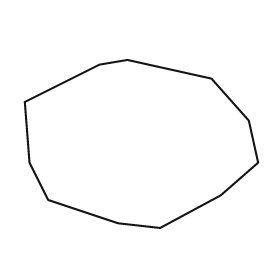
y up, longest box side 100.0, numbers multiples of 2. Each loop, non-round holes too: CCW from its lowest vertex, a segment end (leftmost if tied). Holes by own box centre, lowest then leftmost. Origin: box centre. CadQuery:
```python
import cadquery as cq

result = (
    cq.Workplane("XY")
    .moveTo(8.0, -36.0)
    .lineTo(34.0, -22.0)
    .lineTo(50.0, -8.0)
    .lineTo(46.0, 10.0)
    .lineTo(30.0, 28.0)
    .lineTo(-6.0, 36.0)
    .lineTo(-18.0, 34.0)
    .lineTo(-50.0, 18.0)
    .lineTo(-48.0, -8.0)
    .lineTo(-40.0, -24.0)
    .lineTo(-10.0, -34.0)
    .close()
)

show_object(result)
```